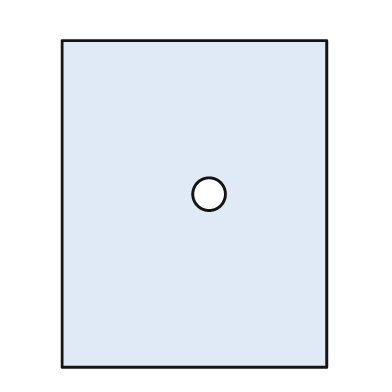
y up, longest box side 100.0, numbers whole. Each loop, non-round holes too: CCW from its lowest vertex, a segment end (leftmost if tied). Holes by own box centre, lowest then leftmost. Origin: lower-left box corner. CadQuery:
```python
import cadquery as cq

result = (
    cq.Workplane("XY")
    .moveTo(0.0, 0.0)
    .lineTo(81.0, 0.0)
    .lineTo(81.0, 100.0)
    .lineTo(0.0, 100.0)
    .close()
    .moveTo(45.0, 53.0)
    .circle(5.0)
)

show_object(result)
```